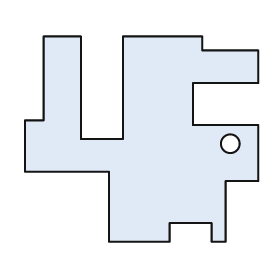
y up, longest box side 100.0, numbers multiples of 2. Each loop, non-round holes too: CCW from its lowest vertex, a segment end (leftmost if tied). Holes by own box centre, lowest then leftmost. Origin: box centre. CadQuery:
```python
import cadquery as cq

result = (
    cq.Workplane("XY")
    .moveTo(-14.0, -44.0)
    .lineTo(12.0, -44.0)
    .lineTo(12.0, -36.0)
    .lineTo(30.0, -36.0)
    .lineTo(30.0, -44.0)
    .lineTo(36.0, -44.0)
    .lineTo(36.0, -18.0)
    .lineTo(50.0, -18.0)
    .lineTo(50.0, 6.0)
    .lineTo(22.0, 6.0)
    .lineTo(22.0, 24.0)
    .lineTo(50.0, 24.0)
    .lineTo(50.0, 38.0)
    .lineTo(26.0, 38.0)
    .lineTo(26.0, 44.0)
    .lineTo(-8.0, 44.0)
    .lineTo(-8.0, 0.0)
    .lineTo(-26.0, 0.0)
    .lineTo(-26.0, 44.0)
    .lineTo(-42.0, 44.0)
    .lineTo(-42.0, 8.0)
    .lineTo(-50.0, 8.0)
    .lineTo(-50.0, -14.0)
    .lineTo(-14.0, -14.0)
    .close()
    .moveTo(38.0, -2.0)
    .circle(4.0)
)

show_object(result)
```